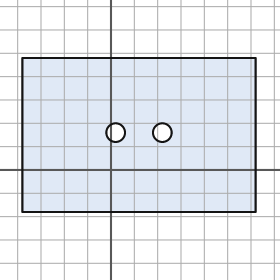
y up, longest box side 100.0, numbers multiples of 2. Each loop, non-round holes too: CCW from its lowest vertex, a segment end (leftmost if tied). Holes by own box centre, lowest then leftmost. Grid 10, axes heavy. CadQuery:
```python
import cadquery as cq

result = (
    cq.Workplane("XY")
    .moveTo(-38.0, -18.0)
    .lineTo(62.0, -18.0)
    .lineTo(62.0, 48.0)
    .lineTo(-38.0, 48.0)
    .close()
    .moveTo(2.0, 16.0)
    .circle(4.0)
    .moveTo(22.0, 16.0)
    .circle(4.0)
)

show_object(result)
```